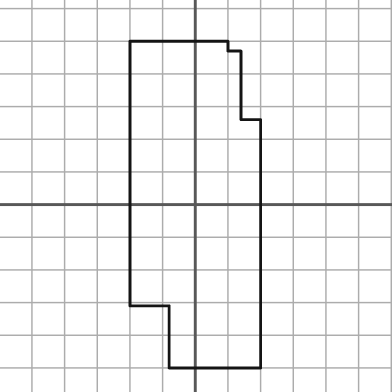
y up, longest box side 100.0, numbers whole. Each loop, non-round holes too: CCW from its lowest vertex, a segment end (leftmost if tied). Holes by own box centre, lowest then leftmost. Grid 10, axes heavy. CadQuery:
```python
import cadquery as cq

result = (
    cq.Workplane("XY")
    .moveTo(-8.0, -50.0)
    .lineTo(20.0, -50.0)
    .lineTo(20.0, 26.0)
    .lineTo(14.0, 26.0)
    .lineTo(14.0, 47.0)
    .lineTo(10.0, 47.0)
    .lineTo(10.0, 50.0)
    .lineTo(-20.0, 50.0)
    .lineTo(-20.0, -31.0)
    .lineTo(-8.0, -31.0)
    .close()
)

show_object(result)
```